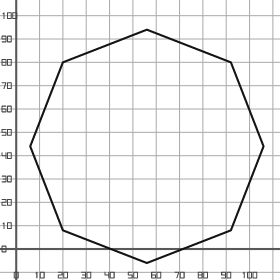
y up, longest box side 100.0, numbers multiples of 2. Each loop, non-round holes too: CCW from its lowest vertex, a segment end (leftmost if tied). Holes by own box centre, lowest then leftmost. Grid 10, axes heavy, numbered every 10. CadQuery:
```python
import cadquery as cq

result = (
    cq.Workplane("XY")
    .moveTo(56.0, -6.0)
    .lineTo(92.0, 8.0)
    .lineTo(106.0, 44.0)
    .lineTo(92.0, 80.0)
    .lineTo(56.0, 94.0)
    .lineTo(20.0, 80.0)
    .lineTo(6.0, 44.0)
    .lineTo(20.0, 8.0)
    .close()
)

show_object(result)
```